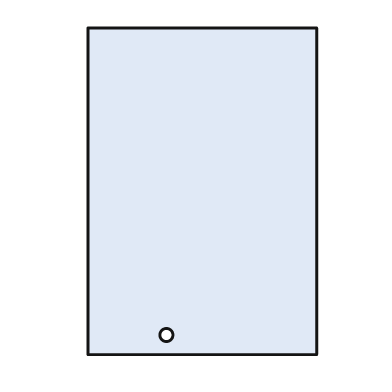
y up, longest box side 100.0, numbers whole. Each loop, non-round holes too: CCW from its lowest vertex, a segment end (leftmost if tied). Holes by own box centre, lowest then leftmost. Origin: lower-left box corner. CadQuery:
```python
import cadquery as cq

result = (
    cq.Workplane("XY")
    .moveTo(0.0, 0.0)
    .lineTo(70.0, 0.0)
    .lineTo(70.0, 100.0)
    .lineTo(0.0, 100.0)
    .close()
    .moveTo(24.0, 6.0)
    .circle(2.0)
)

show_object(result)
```